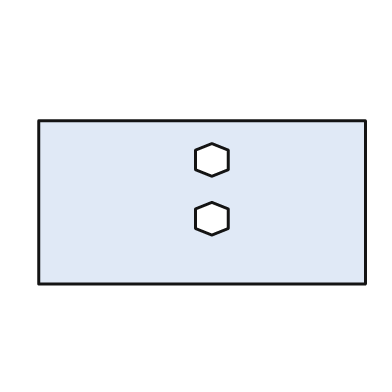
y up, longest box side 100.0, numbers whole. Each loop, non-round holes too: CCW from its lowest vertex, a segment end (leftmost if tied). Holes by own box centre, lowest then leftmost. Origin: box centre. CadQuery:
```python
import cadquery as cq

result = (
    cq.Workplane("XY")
    .moveTo(-50.0, -25.0)
    .lineTo(50.0, -25.0)
    .lineTo(50.0, 25.0)
    .lineTo(-50.0, 25.0)
    .close()
    .moveTo(3.0, -10.0)
    .lineTo(8.0, -8.0)
    .lineTo(8.0, -2.0)
    .lineTo(3.0, 0.0)
    .lineTo(-2.0, -2.0)
    .lineTo(-2.0, -8.0)
    .close()
    .moveTo(3.0, 8.0)
    .lineTo(8.0, 10.0)
    .lineTo(8.0, 16.0)
    .lineTo(3.0, 18.0)
    .lineTo(-2.0, 16.0)
    .lineTo(-2.0, 10.0)
    .close()
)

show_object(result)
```